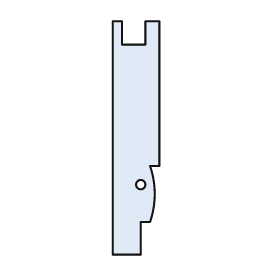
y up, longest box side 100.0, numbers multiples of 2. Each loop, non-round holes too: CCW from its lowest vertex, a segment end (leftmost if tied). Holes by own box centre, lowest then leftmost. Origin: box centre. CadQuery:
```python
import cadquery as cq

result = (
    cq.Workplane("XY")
    .moveTo(-10.0, -50.0)
    .lineTo(2.0, -50.0)
    .lineTo(2.0, -36.0)
    .lineTo(6.0, -36.0)
    .threePointArc((8.0, -24.0), (6.0, -12.0))
    .lineTo(10.0, -12.0)
    .lineTo(10.0, 50.0)
    .lineTo(4.0, 50.0)
    .lineTo(4.0, 40.0)
    .lineTo(-6.0, 40.0)
    .lineTo(-6.0, 50.0)
    .lineTo(-10.0, 50.0)
    .close()
    .moveTo(2.0, -20.0)
    .circle(2.0)
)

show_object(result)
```